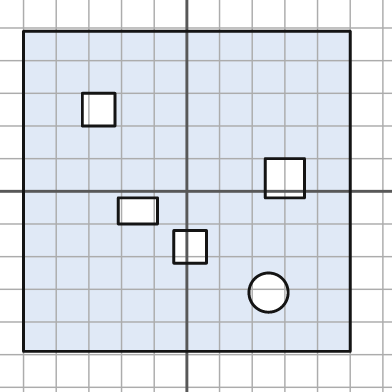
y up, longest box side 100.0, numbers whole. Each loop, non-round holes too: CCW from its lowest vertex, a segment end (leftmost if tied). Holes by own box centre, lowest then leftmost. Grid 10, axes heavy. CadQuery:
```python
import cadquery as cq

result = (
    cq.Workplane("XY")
    .moveTo(-50.0, -49.0)
    .lineTo(50.0, -49.0)
    .lineTo(50.0, 49.0)
    .lineTo(-50.0, 49.0)
    .close()
    .moveTo(25.0, -31.0)
    .circle(6.0)
    .moveTo(-4.0, -22.0)
    .lineTo(6.0, -22.0)
    .lineTo(6.0, -12.0)
    .lineTo(-4.0, -12.0)
    .close()
    .moveTo(-21.0, -10.0)
    .lineTo(-9.0, -10.0)
    .lineTo(-9.0, -2.0)
    .lineTo(-21.0, -2.0)
    .close()
    .moveTo(24.0, -2.0)
    .lineTo(36.0, -2.0)
    .lineTo(36.0, 10.0)
    .lineTo(24.0, 10.0)
    .close()
    .moveTo(-32.0, 20.0)
    .lineTo(-22.0, 20.0)
    .lineTo(-22.0, 30.0)
    .lineTo(-32.0, 30.0)
    .close()
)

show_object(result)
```